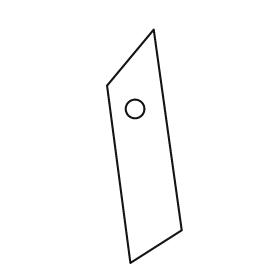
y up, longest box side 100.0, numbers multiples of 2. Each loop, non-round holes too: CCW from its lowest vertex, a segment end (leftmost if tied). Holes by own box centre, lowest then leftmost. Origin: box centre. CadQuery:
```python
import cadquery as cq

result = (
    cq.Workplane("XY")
    .moveTo(-6.0, -50.0)
    .lineTo(16.0, -36.0)
    .lineTo(4.0, 50.0)
    .lineTo(-16.0, 26.0)
    .close()
    .moveTo(-4.0, 16.0)
    .circle(4.0)
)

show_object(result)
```